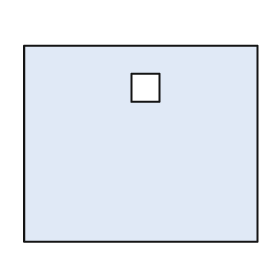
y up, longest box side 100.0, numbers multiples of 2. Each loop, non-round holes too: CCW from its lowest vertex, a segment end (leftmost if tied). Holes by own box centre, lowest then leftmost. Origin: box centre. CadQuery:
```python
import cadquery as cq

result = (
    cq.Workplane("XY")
    .moveTo(-50.0, -42.0)
    .lineTo(50.0, -42.0)
    .lineTo(50.0, 42.0)
    .lineTo(-50.0, 42.0)
    .close()
    .moveTo(-4.0, 18.0)
    .lineTo(8.0, 18.0)
    .lineTo(8.0, 30.0)
    .lineTo(-4.0, 30.0)
    .close()
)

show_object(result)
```